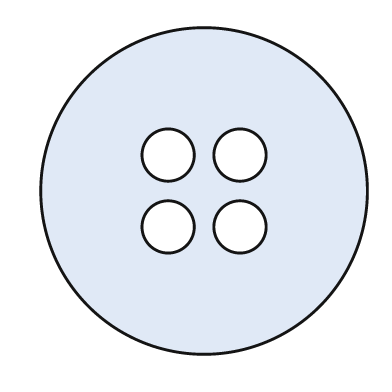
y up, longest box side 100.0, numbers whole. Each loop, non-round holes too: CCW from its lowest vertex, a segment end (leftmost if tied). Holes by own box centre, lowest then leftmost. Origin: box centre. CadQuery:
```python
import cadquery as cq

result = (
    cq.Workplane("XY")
    .moveTo(0.0, 0.0)
    .circle(50.0)
    .moveTo(-11.0, -11.0)
    .circle(8.0)
    .moveTo(11.0, -11.0)
    .circle(8.0)
    .moveTo(-11.0, 11.0)
    .circle(8.0)
    .moveTo(11.0, 11.0)
    .circle(8.0)
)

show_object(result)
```